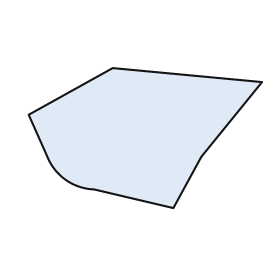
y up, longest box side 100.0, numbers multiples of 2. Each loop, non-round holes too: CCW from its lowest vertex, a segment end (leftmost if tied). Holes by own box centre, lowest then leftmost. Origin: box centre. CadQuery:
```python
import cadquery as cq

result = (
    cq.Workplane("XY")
    .moveTo(12.0, -30.0)
    .lineTo(24.0, -8.0)
    .lineTo(50.0, 24.0)
    .lineTo(-14.0, 30.0)
    .lineTo(-50.0, 10.0)
    .lineTo(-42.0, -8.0)
    .threePointArc((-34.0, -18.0), (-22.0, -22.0))
    .close()
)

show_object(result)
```